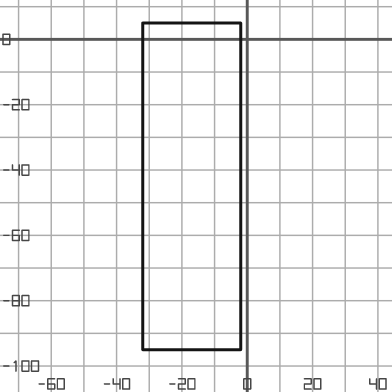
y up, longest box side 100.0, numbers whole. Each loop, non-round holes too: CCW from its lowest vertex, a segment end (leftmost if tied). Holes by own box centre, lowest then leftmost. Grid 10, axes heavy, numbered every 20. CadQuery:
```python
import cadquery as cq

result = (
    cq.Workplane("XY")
    .moveTo(-32.0, -95.0)
    .lineTo(-2.0, -95.0)
    .lineTo(-2.0, 5.0)
    .lineTo(-32.0, 5.0)
    .close()
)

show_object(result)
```